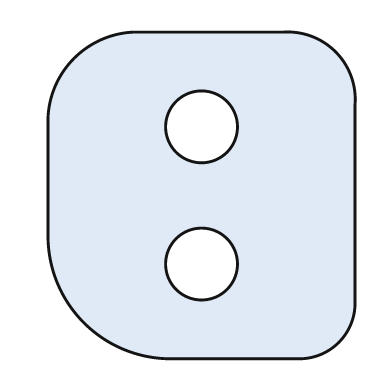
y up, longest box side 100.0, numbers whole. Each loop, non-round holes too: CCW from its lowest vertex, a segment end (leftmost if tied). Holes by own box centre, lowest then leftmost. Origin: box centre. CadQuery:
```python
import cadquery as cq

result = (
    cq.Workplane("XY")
    .moveTo(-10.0, -50.0)
    .lineTo(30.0, -50.0)
    .threePointArc((42.0, -45.0), (47.0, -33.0))
    .lineTo(47.0, 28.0)
    .threePointArc((41.0, 44.0), (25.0, 50.0))
    .lineTo(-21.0, 50.0)
    .threePointArc((-39.0, 42.0), (-47.0, 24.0))
    .lineTo(-47.0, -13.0)
    .threePointArc((-36.0, -39.0), (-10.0, -50.0))
    .close()
    .moveTo(0.0, -21.0)
    .circle(11.0)
    .moveTo(0.0, 21.0)
    .circle(11.0)
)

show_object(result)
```